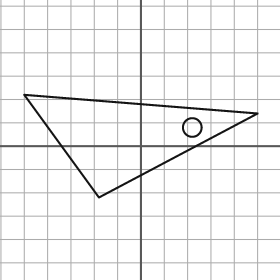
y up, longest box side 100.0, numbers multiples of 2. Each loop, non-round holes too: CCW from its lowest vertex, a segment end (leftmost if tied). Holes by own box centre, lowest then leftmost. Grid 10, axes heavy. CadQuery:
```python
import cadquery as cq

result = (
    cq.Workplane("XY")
    .moveTo(-18.0, -22.0)
    .lineTo(50.0, 14.0)
    .lineTo(-50.0, 22.0)
    .close()
    .moveTo(22.0, 8.0)
    .circle(4.0)
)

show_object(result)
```